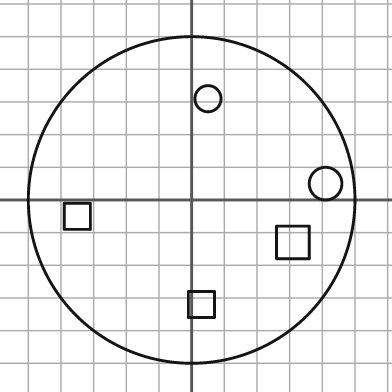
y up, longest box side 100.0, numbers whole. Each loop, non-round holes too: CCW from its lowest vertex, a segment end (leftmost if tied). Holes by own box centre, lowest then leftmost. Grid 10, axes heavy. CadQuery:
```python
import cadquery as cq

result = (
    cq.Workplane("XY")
    .moveTo(0.0, 0.0)
    .circle(50.0)
    .moveTo(-1.0, -36.0)
    .lineTo(7.0, -36.0)
    .lineTo(7.0, -28.0)
    .lineTo(-1.0, -28.0)
    .close()
    .moveTo(26.0, -18.0)
    .lineTo(36.0, -18.0)
    .lineTo(36.0, -8.0)
    .lineTo(26.0, -8.0)
    .close()
    .moveTo(-39.0, -9.0)
    .lineTo(-31.0, -9.0)
    .lineTo(-31.0, -1.0)
    .lineTo(-39.0, -1.0)
    .close()
    .moveTo(41.0, 5.0)
    .circle(5.0)
    .moveTo(5.0, 31.0)
    .circle(4.0)
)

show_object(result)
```